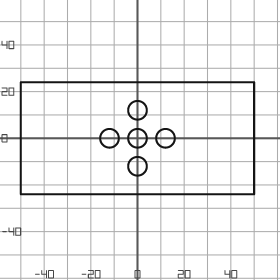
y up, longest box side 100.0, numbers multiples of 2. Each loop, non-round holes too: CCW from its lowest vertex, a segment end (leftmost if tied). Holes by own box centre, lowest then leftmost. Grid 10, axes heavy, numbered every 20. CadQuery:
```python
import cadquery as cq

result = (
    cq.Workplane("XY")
    .moveTo(-50.0, -24.0)
    .lineTo(50.0, -24.0)
    .lineTo(50.0, 24.0)
    .lineTo(-50.0, 24.0)
    .close()
    .moveTo(0.0, -12.0)
    .circle(4.0)
    .moveTo(-12.0, 0.0)
    .circle(4.0)
    .moveTo(0.0, 0.0)
    .circle(4.0)
    .moveTo(12.0, 0.0)
    .circle(4.0)
    .moveTo(0.0, 12.0)
    .circle(4.0)
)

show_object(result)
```